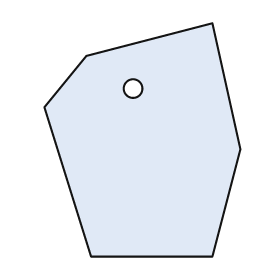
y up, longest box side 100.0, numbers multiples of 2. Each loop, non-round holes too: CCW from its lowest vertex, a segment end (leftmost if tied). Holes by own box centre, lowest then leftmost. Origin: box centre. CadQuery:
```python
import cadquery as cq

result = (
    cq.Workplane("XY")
    .moveTo(-22.0, -50.0)
    .lineTo(30.0, -50.0)
    .lineTo(42.0, -4.0)
    .lineTo(30.0, 50.0)
    .lineTo(-24.0, 36.0)
    .lineTo(-42.0, 14.0)
    .close()
    .moveTo(-4.0, 22.0)
    .circle(4.0)
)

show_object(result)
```